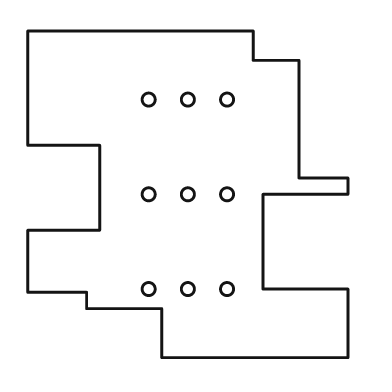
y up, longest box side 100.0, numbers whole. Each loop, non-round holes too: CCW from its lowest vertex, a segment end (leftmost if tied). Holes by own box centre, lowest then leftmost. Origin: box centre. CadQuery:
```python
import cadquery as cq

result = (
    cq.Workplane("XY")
    .moveTo(-8.0, -50.0)
    .lineTo(49.0, -50.0)
    .lineTo(49.0, -29.0)
    .lineTo(23.0, -29.0)
    .lineTo(23.0, 0.0)
    .lineTo(49.0, 0.0)
    .lineTo(49.0, 5.0)
    .lineTo(34.0, 5.0)
    .lineTo(34.0, 41.0)
    .lineTo(20.0, 41.0)
    .lineTo(20.0, 50.0)
    .lineTo(-49.0, 50.0)
    .lineTo(-49.0, 15.0)
    .lineTo(-27.0, 15.0)
    .lineTo(-27.0, -11.0)
    .lineTo(-49.0, -11.0)
    .lineTo(-49.0, -30.0)
    .lineTo(-31.0, -30.0)
    .lineTo(-31.0, -35.0)
    .lineTo(-8.0, -35.0)
    .close()
    .moveTo(-12.0, -29.0)
    .circle(2.0)
    .moveTo(0.0, -29.0)
    .circle(2.0)
    .moveTo(12.0, -29.0)
    .circle(2.0)
    .moveTo(-12.0, 0.0)
    .circle(2.0)
    .moveTo(0.0, 0.0)
    .circle(2.0)
    .moveTo(12.0, 0.0)
    .circle(2.0)
    .moveTo(-12.0, 29.0)
    .circle(2.0)
    .moveTo(0.0, 29.0)
    .circle(2.0)
    .moveTo(12.0, 29.0)
    .circle(2.0)
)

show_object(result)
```